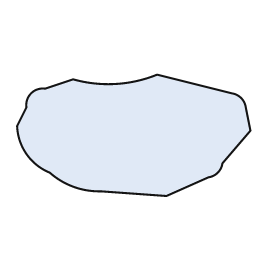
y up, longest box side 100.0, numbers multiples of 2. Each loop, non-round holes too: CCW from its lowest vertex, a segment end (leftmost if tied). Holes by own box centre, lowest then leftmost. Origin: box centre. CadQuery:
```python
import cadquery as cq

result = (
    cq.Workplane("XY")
    .moveTo(14.0, -26.0)
    .lineTo(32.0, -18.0)
    .threePointArc((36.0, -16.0), (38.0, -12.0))
    .lineTo(50.0, 2.0)
    .lineTo(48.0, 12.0)
    .threePointArc((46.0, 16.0), (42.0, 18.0))
    .lineTo(10.0, 26.0)
    .threePointArc((-8.0, 22.0), (-26.0, 24.0))
    .lineTo(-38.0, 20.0)
    .threePointArc((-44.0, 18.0), (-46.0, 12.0))
    .lineTo(-50.0, 4.0)
    .threePointArc((-46.0, -8.0), (-36.0, -16.0))
    .threePointArc((-26.0, -22.0), (-14.0, -24.0))
    .close()
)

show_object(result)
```